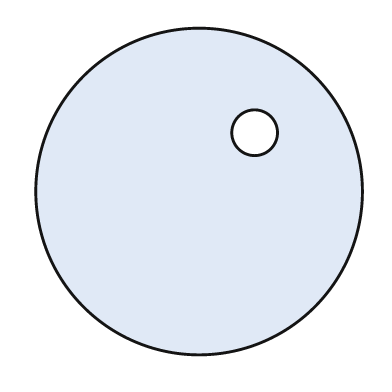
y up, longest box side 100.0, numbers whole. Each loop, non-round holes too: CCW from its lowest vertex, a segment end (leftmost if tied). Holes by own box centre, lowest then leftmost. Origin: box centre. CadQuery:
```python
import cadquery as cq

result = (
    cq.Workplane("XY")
    .moveTo(0.0, 0.0)
    .circle(50.0)
    .moveTo(17.0, 18.0)
    .circle(7.0)
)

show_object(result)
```